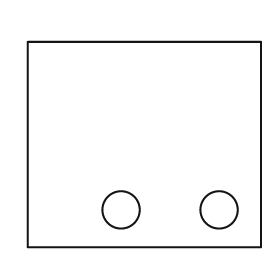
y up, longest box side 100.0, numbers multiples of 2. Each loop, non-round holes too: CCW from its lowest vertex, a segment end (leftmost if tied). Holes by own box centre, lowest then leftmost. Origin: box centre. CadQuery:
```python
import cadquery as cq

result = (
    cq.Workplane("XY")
    .moveTo(-50.0, -44.0)
    .lineTo(50.0, -44.0)
    .lineTo(50.0, 44.0)
    .lineTo(-50.0, 44.0)
    .close()
    .moveTo(-10.0, -28.0)
    .circle(8.0)
    .moveTo(32.0, -28.0)
    .circle(8.0)
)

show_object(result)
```